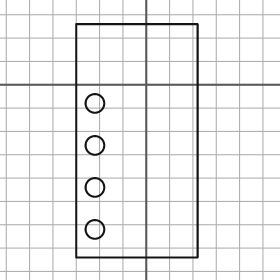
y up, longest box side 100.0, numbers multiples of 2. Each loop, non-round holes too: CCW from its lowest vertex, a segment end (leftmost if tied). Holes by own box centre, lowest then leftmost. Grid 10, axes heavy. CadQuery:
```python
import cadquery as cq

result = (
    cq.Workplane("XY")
    .moveTo(-30.0, -74.0)
    .lineTo(22.0, -74.0)
    .lineTo(22.0, 26.0)
    .lineTo(-30.0, 26.0)
    .close()
    .moveTo(-22.0, -62.0)
    .circle(4.0)
    .moveTo(-22.0, -44.0)
    .circle(4.0)
    .moveTo(-22.0, -26.0)
    .circle(4.0)
    .moveTo(-22.0, -8.0)
    .circle(4.0)
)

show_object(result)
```